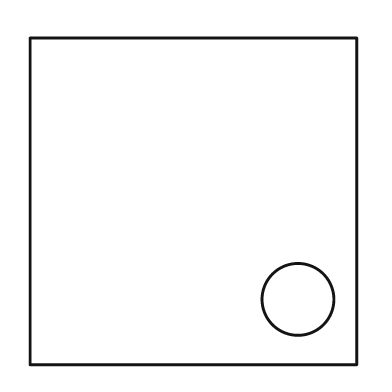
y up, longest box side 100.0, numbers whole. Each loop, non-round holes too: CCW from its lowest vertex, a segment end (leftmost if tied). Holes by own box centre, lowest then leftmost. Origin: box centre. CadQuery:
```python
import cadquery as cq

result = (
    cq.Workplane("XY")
    .moveTo(-50.0, -50.0)
    .lineTo(50.0, -50.0)
    .lineTo(50.0, 50.0)
    .lineTo(-50.0, 50.0)
    .close()
    .moveTo(32.0, -30.0)
    .circle(11.0)
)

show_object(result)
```